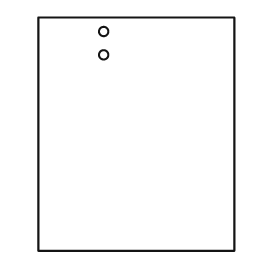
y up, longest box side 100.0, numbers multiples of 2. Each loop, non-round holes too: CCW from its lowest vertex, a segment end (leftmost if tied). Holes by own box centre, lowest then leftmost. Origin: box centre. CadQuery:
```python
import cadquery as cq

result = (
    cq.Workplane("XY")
    .moveTo(-42.0, -50.0)
    .lineTo(42.0, -50.0)
    .lineTo(42.0, 50.0)
    .lineTo(-42.0, 50.0)
    .close()
    .moveTo(-14.0, 34.0)
    .circle(2.0)
    .moveTo(-14.0, 44.0)
    .circle(2.0)
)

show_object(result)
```